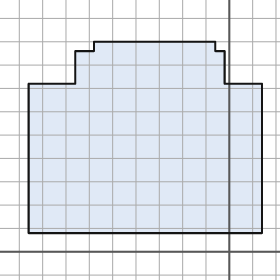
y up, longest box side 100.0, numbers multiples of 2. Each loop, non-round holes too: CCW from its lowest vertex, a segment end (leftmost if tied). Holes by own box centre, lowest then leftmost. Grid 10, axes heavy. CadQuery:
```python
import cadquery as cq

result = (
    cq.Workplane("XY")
    .moveTo(-86.0, 8.0)
    .lineTo(14.0, 8.0)
    .lineTo(14.0, 72.0)
    .lineTo(-2.0, 72.0)
    .lineTo(-2.0, 86.0)
    .lineTo(-6.0, 86.0)
    .lineTo(-6.0, 90.0)
    .lineTo(-58.0, 90.0)
    .lineTo(-58.0, 86.0)
    .lineTo(-66.0, 86.0)
    .lineTo(-66.0, 72.0)
    .lineTo(-86.0, 72.0)
    .close()
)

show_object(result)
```